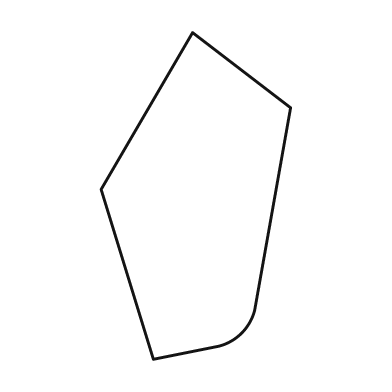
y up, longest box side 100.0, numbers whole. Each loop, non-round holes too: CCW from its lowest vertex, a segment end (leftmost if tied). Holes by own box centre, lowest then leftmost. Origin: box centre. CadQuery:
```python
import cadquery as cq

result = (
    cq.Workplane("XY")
    .moveTo(-13.0, -50.0)
    .lineTo(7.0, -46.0)
    .threePointArc((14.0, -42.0), (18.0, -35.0))
    .lineTo(29.0, 27.0)
    .lineTo(-1.0, 50.0)
    .lineTo(-29.0, 2.0)
    .close()
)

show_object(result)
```